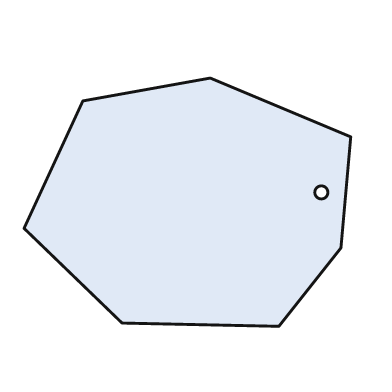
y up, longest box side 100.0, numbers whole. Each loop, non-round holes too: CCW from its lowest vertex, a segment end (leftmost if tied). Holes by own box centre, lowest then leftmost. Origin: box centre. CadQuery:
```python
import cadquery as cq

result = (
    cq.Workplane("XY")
    .moveTo(28.0, -38.0)
    .lineTo(47.0, -14.0)
    .lineTo(50.0, 20.0)
    .lineTo(7.0, 38.0)
    .lineTo(-32.0, 31.0)
    .lineTo(-50.0, -8.0)
    .lineTo(-20.0, -37.0)
    .close()
    .moveTo(41.0, 3.0)
    .circle(2.0)
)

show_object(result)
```